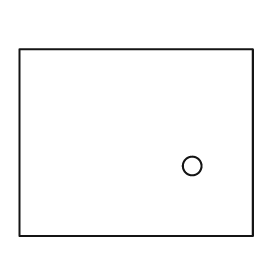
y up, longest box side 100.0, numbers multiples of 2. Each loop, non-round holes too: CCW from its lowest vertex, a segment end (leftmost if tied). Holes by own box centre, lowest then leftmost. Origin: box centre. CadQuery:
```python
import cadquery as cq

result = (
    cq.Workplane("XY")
    .moveTo(-50.0, -40.0)
    .lineTo(50.0, -40.0)
    .lineTo(50.0, 40.0)
    .lineTo(-50.0, 40.0)
    .close()
    .moveTo(24.0, -10.0)
    .circle(4.0)
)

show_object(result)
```